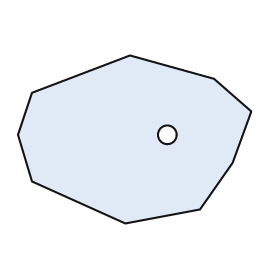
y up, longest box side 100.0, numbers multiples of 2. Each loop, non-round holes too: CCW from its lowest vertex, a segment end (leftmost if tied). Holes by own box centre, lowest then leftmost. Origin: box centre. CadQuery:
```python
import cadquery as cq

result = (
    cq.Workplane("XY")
    .moveTo(-4.0, -36.0)
    .lineTo(28.0, -30.0)
    .lineTo(42.0, -10.0)
    .lineTo(50.0, 12.0)
    .lineTo(34.0, 26.0)
    .lineTo(-2.0, 36.0)
    .lineTo(-44.0, 20.0)
    .lineTo(-50.0, 2.0)
    .lineTo(-44.0, -18.0)
    .close()
    .moveTo(14.0, 2.0)
    .circle(4.0)
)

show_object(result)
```